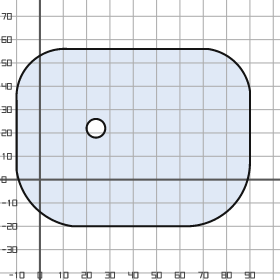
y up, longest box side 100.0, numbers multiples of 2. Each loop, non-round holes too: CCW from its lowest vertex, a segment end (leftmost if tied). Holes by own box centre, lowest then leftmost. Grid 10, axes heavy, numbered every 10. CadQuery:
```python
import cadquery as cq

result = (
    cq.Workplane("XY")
    .moveTo(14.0, -20.0)
    .lineTo(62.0, -20.0)
    .threePointArc((82.0, -12.0), (90.0, 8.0))
    .lineTo(90.0, 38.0)
    .threePointArc((84.0, 50.0), (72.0, 56.0))
    .lineTo(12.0, 56.0)
    .threePointArc((-4.0, 50.0), (-10.0, 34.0))
    .lineTo(-10.0, 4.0)
    .threePointArc((-2.0, -12.0), (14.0, -20.0))
    .close()
    .moveTo(24.0, 22.0)
    .circle(4.0)
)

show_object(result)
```